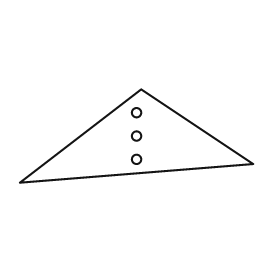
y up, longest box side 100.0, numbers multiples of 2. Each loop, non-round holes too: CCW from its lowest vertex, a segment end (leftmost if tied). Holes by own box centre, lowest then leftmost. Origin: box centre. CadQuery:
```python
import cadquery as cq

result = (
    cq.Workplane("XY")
    .moveTo(-50.0, -20.0)
    .lineTo(50.0, -12.0)
    .lineTo(2.0, 20.0)
    .close()
    .moveTo(0.0, -10.0)
    .circle(2.0)
    .moveTo(0.0, 0.0)
    .circle(2.0)
    .moveTo(0.0, 10.0)
    .circle(2.0)
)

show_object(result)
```